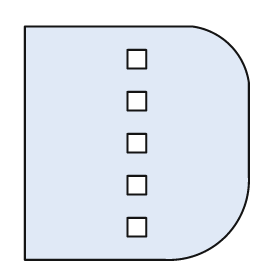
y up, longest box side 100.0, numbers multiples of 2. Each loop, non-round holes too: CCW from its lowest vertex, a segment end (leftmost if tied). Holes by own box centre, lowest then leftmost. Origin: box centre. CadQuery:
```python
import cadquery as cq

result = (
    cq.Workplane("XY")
    .moveTo(-48.0, -50.0)
    .lineTo(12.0, -50.0)
    .threePointArc((38.0, -40.0), (48.0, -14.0))
    .lineTo(48.0, 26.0)
    .threePointArc((40.0, 42.0), (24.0, 50.0))
    .lineTo(-48.0, 50.0)
    .close()
    .moveTo(-4.0, -40.0)
    .lineTo(4.0, -40.0)
    .lineTo(4.0, -32.0)
    .lineTo(-4.0, -32.0)
    .close()
    .moveTo(-4.0, -22.0)
    .lineTo(4.0, -22.0)
    .lineTo(4.0, -14.0)
    .lineTo(-4.0, -14.0)
    .close()
    .moveTo(-4.0, -4.0)
    .lineTo(4.0, -4.0)
    .lineTo(4.0, 4.0)
    .lineTo(-4.0, 4.0)
    .close()
    .moveTo(-4.0, 14.0)
    .lineTo(4.0, 14.0)
    .lineTo(4.0, 22.0)
    .lineTo(-4.0, 22.0)
    .close()
    .moveTo(-4.0, 32.0)
    .lineTo(4.0, 32.0)
    .lineTo(4.0, 40.0)
    .lineTo(-4.0, 40.0)
    .close()
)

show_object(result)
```